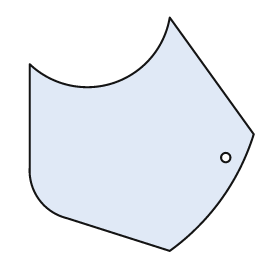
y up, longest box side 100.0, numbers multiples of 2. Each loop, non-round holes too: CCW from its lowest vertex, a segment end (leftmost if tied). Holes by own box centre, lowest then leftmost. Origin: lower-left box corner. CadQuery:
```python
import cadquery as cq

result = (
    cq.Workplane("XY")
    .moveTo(60.0, 0.0)
    .threePointArc((82.0, 22.0), (96.0, 50.0))
    .lineTo(60.0, 100.0)
    .threePointArc((36.0, 72.0), (0.0, 80.0))
    .lineTo(0.0, 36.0)
    .threePointArc((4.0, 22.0), (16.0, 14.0))
    .close()
    .moveTo(84.0, 40.0)
    .circle(2.0)
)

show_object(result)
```